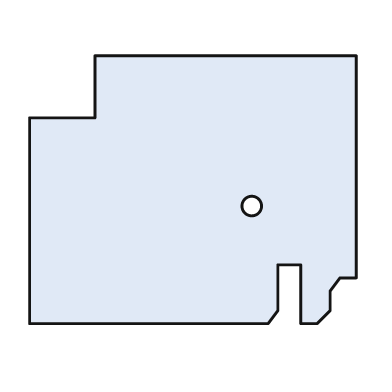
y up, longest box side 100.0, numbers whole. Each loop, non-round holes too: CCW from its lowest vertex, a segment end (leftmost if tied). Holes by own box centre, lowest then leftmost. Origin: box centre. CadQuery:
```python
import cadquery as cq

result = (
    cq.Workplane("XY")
    .moveTo(-50.0, -41.0)
    .lineTo(23.0, -41.0)
    .lineTo(26.0, -37.0)
    .lineTo(26.0, -23.0)
    .lineTo(33.0, -23.0)
    .lineTo(33.0, -41.0)
    .lineTo(38.0, -41.0)
    .lineTo(42.0, -37.0)
    .lineTo(42.0, -31.0)
    .lineTo(45.0, -27.0)
    .lineTo(50.0, -27.0)
    .lineTo(50.0, 41.0)
    .lineTo(-30.0, 41.0)
    .lineTo(-30.0, 22.0)
    .lineTo(-50.0, 22.0)
    .close()
    .moveTo(18.0, -5.0)
    .circle(3.0)
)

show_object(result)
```